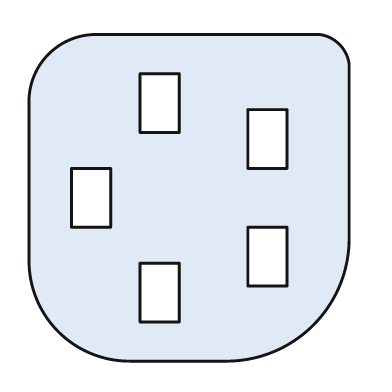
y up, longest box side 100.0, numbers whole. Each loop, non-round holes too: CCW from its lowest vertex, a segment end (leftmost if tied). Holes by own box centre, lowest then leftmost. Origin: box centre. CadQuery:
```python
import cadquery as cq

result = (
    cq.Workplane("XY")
    .moveTo(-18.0, -50.0)
    .lineTo(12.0, -50.0)
    .threePointArc((38.0, -39.0), (49.0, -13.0))
    .lineTo(49.0, 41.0)
    .threePointArc((46.0, 47.0), (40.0, 50.0))
    .lineTo(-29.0, 50.0)
    .threePointArc((-43.0, 44.0), (-49.0, 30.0))
    .lineTo(-49.0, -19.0)
    .threePointArc((-40.0, -41.0), (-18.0, -50.0))
    .close()
    .moveTo(-15.0, -38.0)
    .lineTo(-3.0, -38.0)
    .lineTo(-3.0, -20.0)
    .lineTo(-15.0, -20.0)
    .close()
    .moveTo(18.0, -27.0)
    .lineTo(30.0, -27.0)
    .lineTo(30.0, -9.0)
    .lineTo(18.0, -9.0)
    .close()
    .moveTo(-36.0, -9.0)
    .lineTo(-24.0, -9.0)
    .lineTo(-24.0, 9.0)
    .lineTo(-36.0, 9.0)
    .close()
    .moveTo(18.0, 9.0)
    .lineTo(30.0, 9.0)
    .lineTo(30.0, 27.0)
    .lineTo(18.0, 27.0)
    .close()
    .moveTo(-15.0, 20.0)
    .lineTo(-3.0, 20.0)
    .lineTo(-3.0, 38.0)
    .lineTo(-15.0, 38.0)
    .close()
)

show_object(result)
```